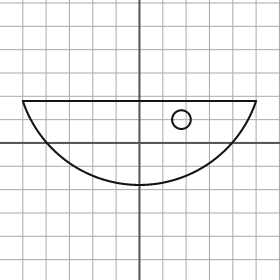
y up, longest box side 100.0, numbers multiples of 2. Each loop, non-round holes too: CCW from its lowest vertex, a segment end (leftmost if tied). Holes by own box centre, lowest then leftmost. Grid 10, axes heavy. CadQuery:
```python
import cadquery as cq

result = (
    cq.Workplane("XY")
    .moveTo(-50.0, 18.0)
    .threePointArc((0.0, -18.0), (50.0, 18.0))
    .close()
    .moveTo(18.0, 10.0)
    .circle(4.0)
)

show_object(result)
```